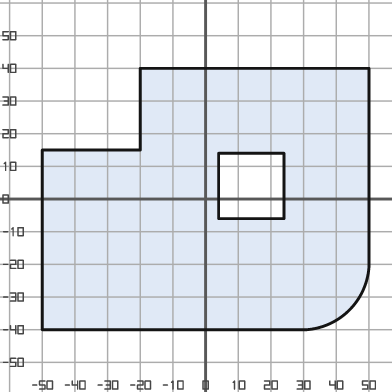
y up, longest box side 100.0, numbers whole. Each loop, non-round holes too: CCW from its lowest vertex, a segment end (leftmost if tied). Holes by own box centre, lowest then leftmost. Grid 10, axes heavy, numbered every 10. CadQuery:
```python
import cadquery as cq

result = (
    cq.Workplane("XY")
    .moveTo(-50.0, -40.0)
    .lineTo(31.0, -40.0)
    .threePointArc((44.0, -34.0), (50.0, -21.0))
    .lineTo(50.0, 40.0)
    .lineTo(-20.0, 40.0)
    .lineTo(-20.0, 15.0)
    .lineTo(-50.0, 15.0)
    .close()
    .moveTo(4.0, -6.0)
    .lineTo(24.0, -6.0)
    .lineTo(24.0, 14.0)
    .lineTo(4.0, 14.0)
    .close()
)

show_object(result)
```